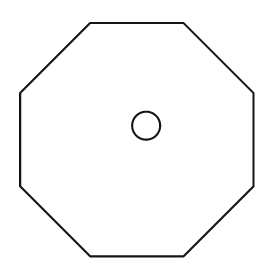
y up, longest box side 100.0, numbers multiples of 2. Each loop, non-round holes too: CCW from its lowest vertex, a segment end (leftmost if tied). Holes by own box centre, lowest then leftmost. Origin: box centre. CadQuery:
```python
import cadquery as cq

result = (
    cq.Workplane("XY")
    .moveTo(-20.0, -50.0)
    .lineTo(20.0, -50.0)
    .lineTo(50.0, -20.0)
    .lineTo(50.0, 20.0)
    .lineTo(20.0, 50.0)
    .lineTo(-20.0, 50.0)
    .lineTo(-50.0, 20.0)
    .lineTo(-50.0, -20.0)
    .close()
    .moveTo(4.0, 6.0)
    .circle(6.0)
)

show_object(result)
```